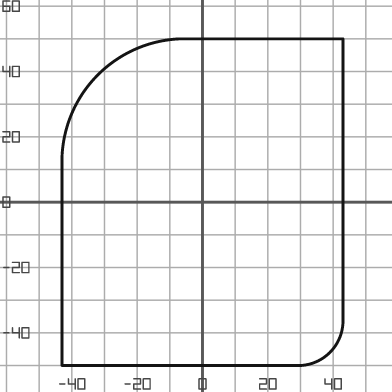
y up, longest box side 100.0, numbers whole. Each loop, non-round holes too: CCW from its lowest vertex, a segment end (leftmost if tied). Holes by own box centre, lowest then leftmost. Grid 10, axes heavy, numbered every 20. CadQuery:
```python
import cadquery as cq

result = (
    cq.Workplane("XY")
    .moveTo(-43.0, -50.0)
    .lineTo(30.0, -50.0)
    .threePointArc((39.0, -46.0), (43.0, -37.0))
    .lineTo(43.0, 50.0)
    .lineTo(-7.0, 50.0)
    .threePointArc((-32.0, 39.0), (-43.0, 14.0))
    .close()
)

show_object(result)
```